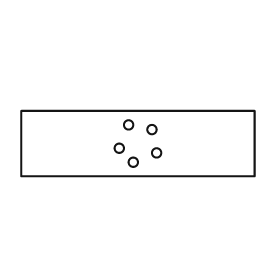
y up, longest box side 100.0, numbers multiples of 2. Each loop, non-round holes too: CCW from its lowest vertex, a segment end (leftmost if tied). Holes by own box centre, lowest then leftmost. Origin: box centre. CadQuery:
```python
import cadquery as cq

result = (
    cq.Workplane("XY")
    .moveTo(-50.0, -14.0)
    .lineTo(50.0, -14.0)
    .lineTo(50.0, 14.0)
    .lineTo(-50.0, 14.0)
    .close()
    .moveTo(-2.0, -8.0)
    .circle(2.0)
    .moveTo(8.0, -4.0)
    .circle(2.0)
    .moveTo(-8.0, -2.0)
    .circle(2.0)
    .moveTo(6.0, 6.0)
    .circle(2.0)
    .moveTo(-4.0, 8.0)
    .circle(2.0)
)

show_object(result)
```